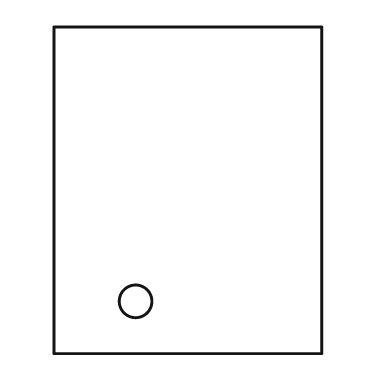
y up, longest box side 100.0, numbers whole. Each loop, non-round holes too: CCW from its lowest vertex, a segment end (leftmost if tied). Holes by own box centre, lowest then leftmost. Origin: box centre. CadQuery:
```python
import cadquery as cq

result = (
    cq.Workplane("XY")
    .moveTo(-41.0, -50.0)
    .lineTo(41.0, -50.0)
    .lineTo(41.0, 50.0)
    .lineTo(-41.0, 50.0)
    .close()
    .moveTo(-16.0, -34.0)
    .circle(5.0)
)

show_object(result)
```